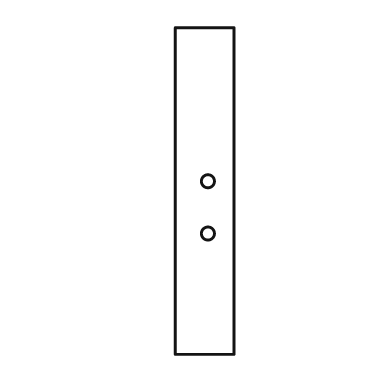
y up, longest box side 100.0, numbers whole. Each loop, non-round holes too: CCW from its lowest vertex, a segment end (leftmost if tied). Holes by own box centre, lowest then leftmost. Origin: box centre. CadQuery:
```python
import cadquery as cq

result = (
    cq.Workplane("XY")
    .moveTo(-9.0, -50.0)
    .lineTo(9.0, -50.0)
    .lineTo(9.0, 50.0)
    .lineTo(-9.0, 50.0)
    .close()
    .moveTo(1.0, -13.0)
    .circle(2.0)
    .moveTo(1.0, 3.0)
    .circle(2.0)
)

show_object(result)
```